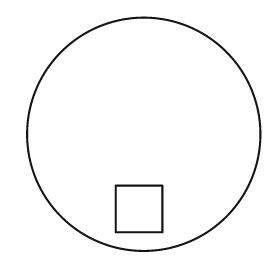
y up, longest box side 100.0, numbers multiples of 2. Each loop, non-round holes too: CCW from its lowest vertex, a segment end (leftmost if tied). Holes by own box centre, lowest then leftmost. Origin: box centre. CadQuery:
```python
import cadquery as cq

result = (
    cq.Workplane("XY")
    .moveTo(0.0, 0.0)
    .circle(50.0)
    .moveTo(-12.0, -42.0)
    .lineTo(8.0, -42.0)
    .lineTo(8.0, -22.0)
    .lineTo(-12.0, -22.0)
    .close()
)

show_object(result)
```